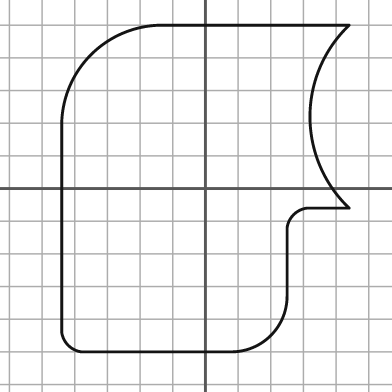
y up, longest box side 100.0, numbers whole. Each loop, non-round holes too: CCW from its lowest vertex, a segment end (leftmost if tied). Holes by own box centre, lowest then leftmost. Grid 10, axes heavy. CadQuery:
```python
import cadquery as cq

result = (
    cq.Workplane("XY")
    .moveTo(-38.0, -50.0)
    .lineTo(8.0, -50.0)
    .threePointArc((20.0, -45.0), (25.0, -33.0))
    .lineTo(25.0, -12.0)
    .threePointArc((27.0, -8.0), (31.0, -6.0))
    .lineTo(44.0, -6.0)
    .threePointArc((32.0, 22.0), (44.0, 50.0))
    .lineTo(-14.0, 50.0)
    .threePointArc((-35.0, 41.0), (-44.0, 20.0))
    .lineTo(-44.0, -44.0)
    .threePointArc((-42.0, -48.0), (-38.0, -50.0))
    .close()
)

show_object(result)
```